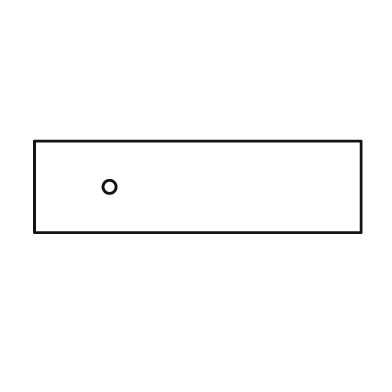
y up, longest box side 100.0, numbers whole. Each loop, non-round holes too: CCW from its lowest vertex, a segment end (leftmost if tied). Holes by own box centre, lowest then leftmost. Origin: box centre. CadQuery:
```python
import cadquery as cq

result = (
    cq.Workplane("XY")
    .moveTo(-50.0, -14.0)
    .lineTo(50.0, -14.0)
    .lineTo(50.0, 14.0)
    .lineTo(-50.0, 14.0)
    .close()
    .moveTo(-27.0, 0.0)
    .circle(2.0)
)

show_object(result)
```